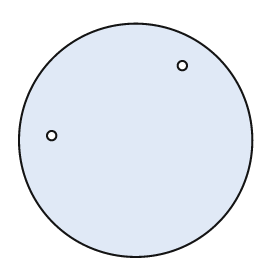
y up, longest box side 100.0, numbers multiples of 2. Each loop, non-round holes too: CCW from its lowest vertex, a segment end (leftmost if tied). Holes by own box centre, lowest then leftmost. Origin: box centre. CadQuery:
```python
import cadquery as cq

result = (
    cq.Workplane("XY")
    .moveTo(0.0, 0.0)
    .circle(50.0)
    .moveTo(-36.0, 2.0)
    .circle(2.0)
    .moveTo(20.0, 32.0)
    .circle(2.0)
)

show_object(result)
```